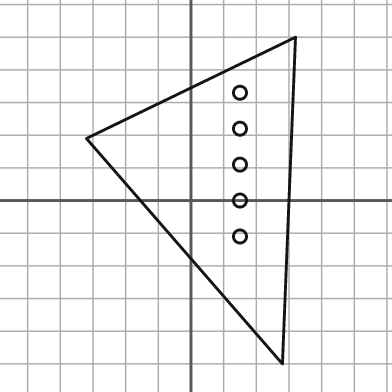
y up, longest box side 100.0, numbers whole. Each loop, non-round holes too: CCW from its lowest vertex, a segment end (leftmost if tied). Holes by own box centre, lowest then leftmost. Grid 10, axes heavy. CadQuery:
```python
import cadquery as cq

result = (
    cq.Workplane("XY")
    .moveTo(28.0, -50.0)
    .lineTo(32.0, 50.0)
    .lineTo(-32.0, 19.0)
    .close()
    .moveTo(15.0, -11.0)
    .circle(2.0)
    .moveTo(15.0, 0.0)
    .circle(2.0)
    .moveTo(15.0, 11.0)
    .circle(2.0)
    .moveTo(15.0, 22.0)
    .circle(2.0)
    .moveTo(15.0, 33.0)
    .circle(2.0)
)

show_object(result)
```